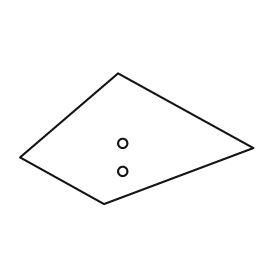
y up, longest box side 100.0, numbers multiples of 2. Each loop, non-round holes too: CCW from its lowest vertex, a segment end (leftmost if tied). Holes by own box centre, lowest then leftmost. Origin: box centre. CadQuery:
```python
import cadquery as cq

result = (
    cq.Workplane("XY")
    .moveTo(-14.0, -28.0)
    .lineTo(50.0, -4.0)
    .lineTo(-8.0, 28.0)
    .lineTo(-50.0, -8.0)
    .close()
    .moveTo(-6.0, -14.0)
    .circle(2.0)
    .moveTo(-6.0, -2.0)
    .circle(2.0)
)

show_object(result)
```